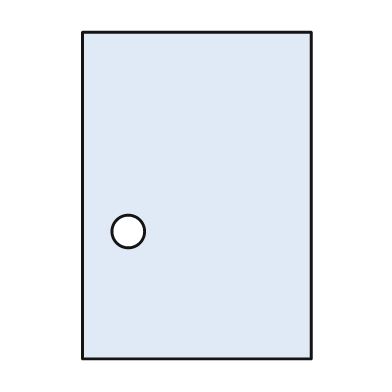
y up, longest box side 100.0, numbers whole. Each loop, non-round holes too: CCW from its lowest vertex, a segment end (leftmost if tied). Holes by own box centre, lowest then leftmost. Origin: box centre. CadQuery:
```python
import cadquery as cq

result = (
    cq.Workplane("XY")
    .moveTo(-35.0, -50.0)
    .lineTo(35.0, -50.0)
    .lineTo(35.0, 50.0)
    .lineTo(-35.0, 50.0)
    .close()
    .moveTo(-21.0, -11.0)
    .circle(5.0)
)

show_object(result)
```